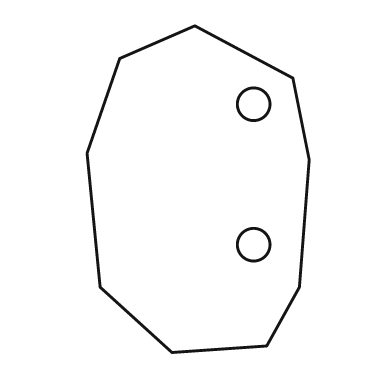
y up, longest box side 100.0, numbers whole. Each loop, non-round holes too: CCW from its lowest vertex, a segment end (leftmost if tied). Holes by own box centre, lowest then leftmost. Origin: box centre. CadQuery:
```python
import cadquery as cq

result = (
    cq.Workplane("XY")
    .moveTo(-8.0, -50.0)
    .lineTo(21.0, -48.0)
    .lineTo(31.0, -30.0)
    .lineTo(34.0, 9.0)
    .lineTo(29.0, 34.0)
    .lineTo(-1.0, 50.0)
    .lineTo(-24.0, 40.0)
    .lineTo(-34.0, 11.0)
    .lineTo(-30.0, -30.0)
    .close()
    .moveTo(17.0, -17.0)
    .circle(5.0)
    .moveTo(17.0, 26.0)
    .circle(5.0)
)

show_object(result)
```